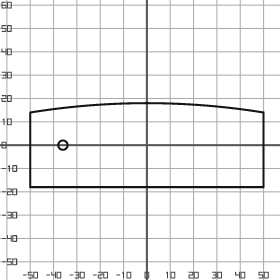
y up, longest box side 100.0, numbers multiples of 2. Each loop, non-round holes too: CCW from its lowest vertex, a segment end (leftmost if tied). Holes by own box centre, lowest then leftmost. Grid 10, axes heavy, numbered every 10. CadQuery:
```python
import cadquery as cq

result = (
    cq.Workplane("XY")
    .moveTo(-50.0, -18.0)
    .lineTo(50.0, -18.0)
    .lineTo(50.0, 14.0)
    .threePointArc((0.0, 18.0), (-50.0, 14.0))
    .close()
    .moveTo(-36.0, 0.0)
    .circle(2.0)
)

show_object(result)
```